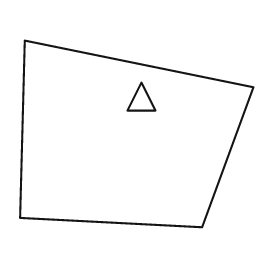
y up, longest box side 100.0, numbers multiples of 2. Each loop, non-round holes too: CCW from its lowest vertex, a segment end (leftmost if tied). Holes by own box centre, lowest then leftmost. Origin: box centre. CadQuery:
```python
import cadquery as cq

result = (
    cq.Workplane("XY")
    .moveTo(28.0, -40.0)
    .lineTo(50.0, 20.0)
    .lineTo(-48.0, 40.0)
    .lineTo(-50.0, -36.0)
    .close()
    .moveTo(-4.0, 10.0)
    .lineTo(8.0, 10.0)
    .lineTo(2.0, 22.0)
    .close()
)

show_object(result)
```